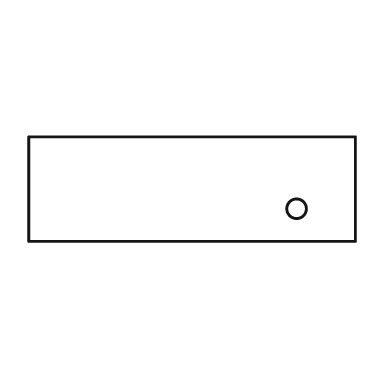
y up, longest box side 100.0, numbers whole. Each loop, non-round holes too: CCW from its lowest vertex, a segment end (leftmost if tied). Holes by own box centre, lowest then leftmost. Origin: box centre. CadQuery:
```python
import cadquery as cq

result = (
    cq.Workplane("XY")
    .moveTo(-50.0, -16.0)
    .lineTo(50.0, -16.0)
    .lineTo(50.0, 16.0)
    .lineTo(-50.0, 16.0)
    .close()
    .moveTo(32.0, -6.0)
    .circle(3.0)
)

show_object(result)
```